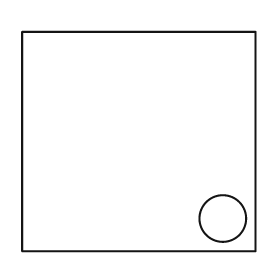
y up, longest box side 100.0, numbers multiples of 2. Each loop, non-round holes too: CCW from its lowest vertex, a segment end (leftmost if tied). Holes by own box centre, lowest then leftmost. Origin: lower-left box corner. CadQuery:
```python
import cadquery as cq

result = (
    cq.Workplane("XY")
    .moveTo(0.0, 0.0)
    .lineTo(100.0, 0.0)
    .lineTo(100.0, 94.0)
    .lineTo(0.0, 94.0)
    .close()
    .moveTo(86.0, 14.0)
    .circle(10.0)
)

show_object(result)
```